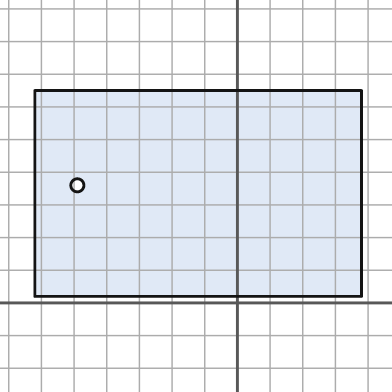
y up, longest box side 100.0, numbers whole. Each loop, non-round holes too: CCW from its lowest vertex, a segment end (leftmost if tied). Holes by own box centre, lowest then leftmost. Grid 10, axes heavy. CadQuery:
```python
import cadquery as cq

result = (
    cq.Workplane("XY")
    .moveTo(-62.0, 2.0)
    .lineTo(38.0, 2.0)
    .lineTo(38.0, 65.0)
    .lineTo(-62.0, 65.0)
    .close()
    .moveTo(-49.0, 36.0)
    .circle(2.0)
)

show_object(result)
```